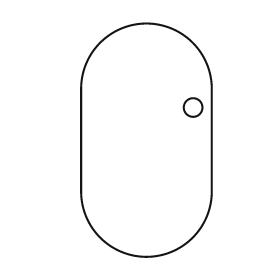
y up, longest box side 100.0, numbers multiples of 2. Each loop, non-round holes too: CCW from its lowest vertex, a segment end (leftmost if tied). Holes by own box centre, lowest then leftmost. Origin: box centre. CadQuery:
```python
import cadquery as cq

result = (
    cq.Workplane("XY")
    .moveTo(-28.0, -22.0)
    .threePointArc((0.0, -50.0), (28.0, -22.0))
    .lineTo(28.0, 22.0)
    .threePointArc((0.0, 50.0), (-28.0, 22.0))
    .close()
    .moveTo(20.0, 14.0)
    .circle(4.0)
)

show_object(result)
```